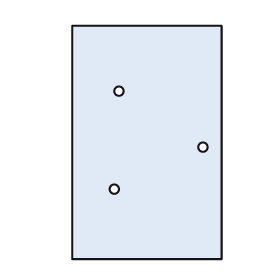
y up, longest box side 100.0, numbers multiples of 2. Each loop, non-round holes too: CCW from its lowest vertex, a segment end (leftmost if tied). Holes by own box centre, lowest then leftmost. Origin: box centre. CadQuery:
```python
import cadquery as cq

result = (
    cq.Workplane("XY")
    .moveTo(-32.0, -50.0)
    .lineTo(32.0, -50.0)
    .lineTo(32.0, 50.0)
    .lineTo(-32.0, 50.0)
    .close()
    .moveTo(-14.0, -20.0)
    .circle(2.0)
    .moveTo(24.0, -2.0)
    .circle(2.0)
    .moveTo(-12.0, 22.0)
    .circle(2.0)
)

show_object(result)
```